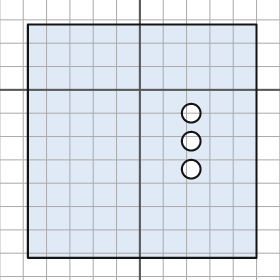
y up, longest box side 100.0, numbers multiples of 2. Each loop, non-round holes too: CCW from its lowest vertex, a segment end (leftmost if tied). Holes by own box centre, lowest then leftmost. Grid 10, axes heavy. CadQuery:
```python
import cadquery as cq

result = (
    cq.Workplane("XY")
    .moveTo(-48.0, -72.0)
    .lineTo(50.0, -72.0)
    .lineTo(50.0, 28.0)
    .lineTo(-48.0, 28.0)
    .close()
    .moveTo(22.0, -34.0)
    .circle(4.0)
    .moveTo(22.0, -22.0)
    .circle(4.0)
    .moveTo(22.0, -10.0)
    .circle(4.0)
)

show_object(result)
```